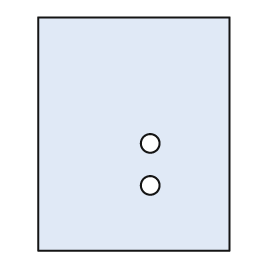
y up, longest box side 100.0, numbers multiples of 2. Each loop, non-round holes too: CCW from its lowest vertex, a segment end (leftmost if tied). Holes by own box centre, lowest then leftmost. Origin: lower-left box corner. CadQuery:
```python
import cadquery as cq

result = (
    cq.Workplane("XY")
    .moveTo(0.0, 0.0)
    .lineTo(82.0, 0.0)
    .lineTo(82.0, 100.0)
    .lineTo(0.0, 100.0)
    .close()
    .moveTo(48.0, 28.0)
    .circle(4.0)
    .moveTo(48.0, 46.0)
    .circle(4.0)
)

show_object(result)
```